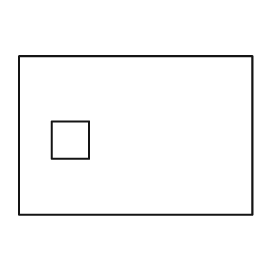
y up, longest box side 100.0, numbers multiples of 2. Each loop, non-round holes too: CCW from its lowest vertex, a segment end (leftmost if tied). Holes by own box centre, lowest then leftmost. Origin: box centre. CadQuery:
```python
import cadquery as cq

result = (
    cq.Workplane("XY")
    .moveTo(-50.0, -34.0)
    .lineTo(50.0, -34.0)
    .lineTo(50.0, 34.0)
    .lineTo(-50.0, 34.0)
    .close()
    .moveTo(-36.0, -10.0)
    .lineTo(-20.0, -10.0)
    .lineTo(-20.0, 6.0)
    .lineTo(-36.0, 6.0)
    .close()
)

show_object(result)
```